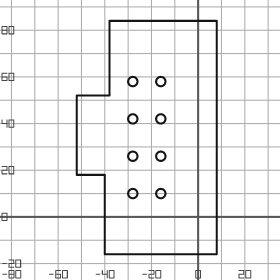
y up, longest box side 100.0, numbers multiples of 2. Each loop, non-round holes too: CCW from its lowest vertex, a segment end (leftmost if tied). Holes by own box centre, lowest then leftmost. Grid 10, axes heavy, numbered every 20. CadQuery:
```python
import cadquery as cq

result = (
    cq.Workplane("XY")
    .moveTo(-40.0, -16.0)
    .lineTo(8.0, -16.0)
    .lineTo(8.0, 84.0)
    .lineTo(-38.0, 84.0)
    .lineTo(-38.0, 52.0)
    .lineTo(-52.0, 52.0)
    .lineTo(-52.0, 18.0)
    .lineTo(-40.0, 18.0)
    .close()
    .moveTo(-28.0, 10.0)
    .circle(2.0)
    .moveTo(-16.0, 10.0)
    .circle(2.0)
    .moveTo(-28.0, 26.0)
    .circle(2.0)
    .moveTo(-16.0, 26.0)
    .circle(2.0)
    .moveTo(-28.0, 42.0)
    .circle(2.0)
    .moveTo(-16.0, 42.0)
    .circle(2.0)
    .moveTo(-28.0, 58.0)
    .circle(2.0)
    .moveTo(-16.0, 58.0)
    .circle(2.0)
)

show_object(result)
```